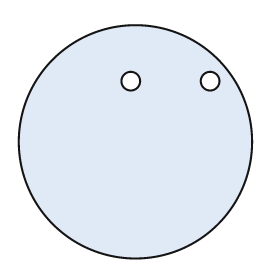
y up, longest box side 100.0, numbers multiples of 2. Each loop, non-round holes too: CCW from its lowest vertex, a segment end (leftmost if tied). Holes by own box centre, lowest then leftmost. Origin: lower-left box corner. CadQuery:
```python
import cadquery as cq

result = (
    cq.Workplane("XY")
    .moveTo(50.0, 50.0)
    .circle(50.0)
    .moveTo(48.0, 76.0)
    .circle(4.0)
    .moveTo(82.0, 76.0)
    .circle(4.0)
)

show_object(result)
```